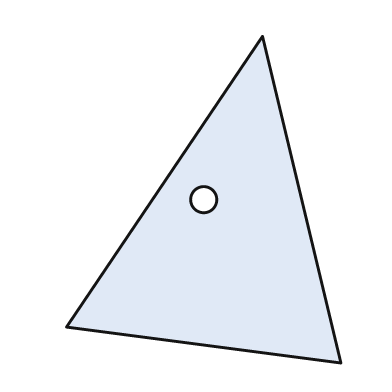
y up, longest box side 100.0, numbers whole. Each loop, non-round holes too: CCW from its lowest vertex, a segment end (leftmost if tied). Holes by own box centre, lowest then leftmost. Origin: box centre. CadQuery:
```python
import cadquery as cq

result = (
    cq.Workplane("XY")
    .moveTo(42.0, -50.0)
    .lineTo(18.0, 50.0)
    .lineTo(-42.0, -39.0)
    .close()
    .moveTo(0.0, 0.0)
    .circle(4.0)
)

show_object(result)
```